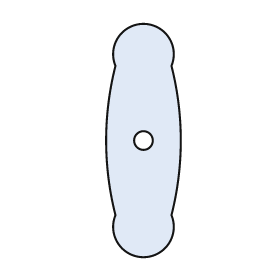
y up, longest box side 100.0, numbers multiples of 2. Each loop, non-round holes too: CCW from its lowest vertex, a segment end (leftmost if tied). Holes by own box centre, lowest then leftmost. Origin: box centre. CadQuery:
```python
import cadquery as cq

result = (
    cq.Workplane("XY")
    .moveTo(-12.0, -32.0)
    .threePointArc((0.0, -50.0), (12.0, -32.0))
    .threePointArc((16.0, 0.0), (12.0, 32.0))
    .threePointArc((0.0, 50.0), (-12.0, 32.0))
    .threePointArc((-16.0, 0.0), (-12.0, -32.0))
    .close()
    .moveTo(0.0, 0.0)
    .circle(4.0)
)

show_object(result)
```